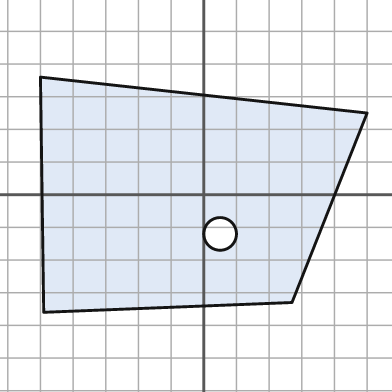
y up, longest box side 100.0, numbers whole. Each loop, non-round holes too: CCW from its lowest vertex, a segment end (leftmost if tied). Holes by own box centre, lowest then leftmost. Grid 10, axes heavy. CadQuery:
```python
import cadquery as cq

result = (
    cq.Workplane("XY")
    .moveTo(-49.0, -36.0)
    .lineTo(27.0, -33.0)
    .lineTo(50.0, 25.0)
    .lineTo(-50.0, 36.0)
    .close()
    .moveTo(5.0, -12.0)
    .circle(5.0)
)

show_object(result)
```